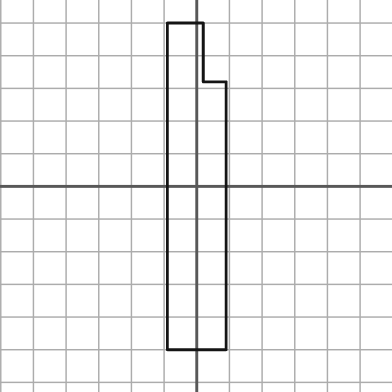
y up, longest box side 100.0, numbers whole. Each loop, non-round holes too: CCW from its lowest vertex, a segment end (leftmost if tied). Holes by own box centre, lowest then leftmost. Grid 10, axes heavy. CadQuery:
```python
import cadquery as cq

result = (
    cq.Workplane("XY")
    .moveTo(-9.0, -50.0)
    .lineTo(9.0, -50.0)
    .lineTo(9.0, 32.0)
    .lineTo(2.0, 32.0)
    .lineTo(2.0, 50.0)
    .lineTo(-9.0, 50.0)
    .close()
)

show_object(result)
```